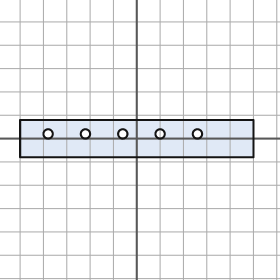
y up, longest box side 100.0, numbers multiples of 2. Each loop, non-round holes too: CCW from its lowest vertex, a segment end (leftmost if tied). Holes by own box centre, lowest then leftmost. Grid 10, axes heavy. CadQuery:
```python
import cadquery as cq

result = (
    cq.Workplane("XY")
    .moveTo(-50.0, -8.0)
    .lineTo(50.0, -8.0)
    .lineTo(50.0, 8.0)
    .lineTo(-50.0, 8.0)
    .close()
    .moveTo(-38.0, 2.0)
    .circle(2.0)
    .moveTo(-22.0, 2.0)
    .circle(2.0)
    .moveTo(-6.0, 2.0)
    .circle(2.0)
    .moveTo(10.0, 2.0)
    .circle(2.0)
    .moveTo(26.0, 2.0)
    .circle(2.0)
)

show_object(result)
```